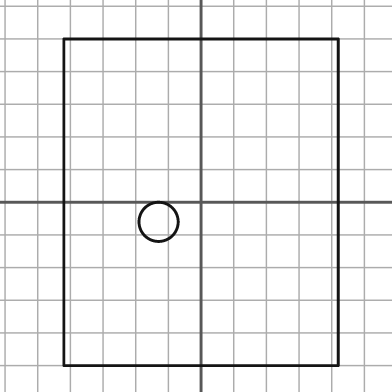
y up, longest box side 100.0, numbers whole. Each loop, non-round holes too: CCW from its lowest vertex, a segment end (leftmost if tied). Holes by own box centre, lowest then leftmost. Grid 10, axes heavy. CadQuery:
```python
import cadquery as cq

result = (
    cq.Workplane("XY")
    .moveTo(-42.0, -50.0)
    .lineTo(42.0, -50.0)
    .lineTo(42.0, 50.0)
    .lineTo(-42.0, 50.0)
    .close()
    .moveTo(-13.0, -6.0)
    .circle(6.0)
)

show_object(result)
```